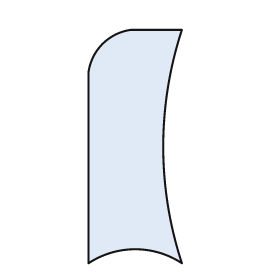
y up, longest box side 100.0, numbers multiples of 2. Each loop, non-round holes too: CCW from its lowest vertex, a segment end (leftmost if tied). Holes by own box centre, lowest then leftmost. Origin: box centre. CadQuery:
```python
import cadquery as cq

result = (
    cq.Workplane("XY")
    .moveTo(-20.0, -50.0)
    .threePointArc((0.0, -44.0), (20.0, -50.0))
    .threePointArc((12.0, 0.0), (20.0, 50.0))
    .lineTo(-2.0, 50.0)
    .threePointArc((-14.0, 44.0), (-20.0, 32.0))
    .close()
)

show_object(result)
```